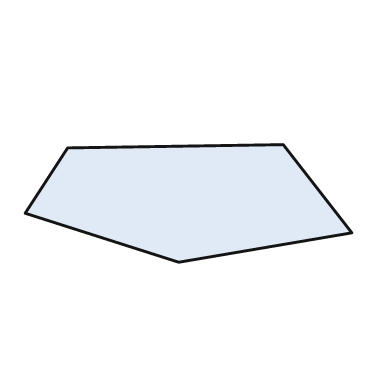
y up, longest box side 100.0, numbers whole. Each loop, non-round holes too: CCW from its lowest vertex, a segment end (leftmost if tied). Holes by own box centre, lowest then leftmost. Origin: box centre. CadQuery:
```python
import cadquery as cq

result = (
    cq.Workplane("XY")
    .moveTo(-3.0, -18.0)
    .lineTo(50.0, -9.0)
    .lineTo(29.0, 18.0)
    .lineTo(-37.0, 17.0)
    .lineTo(-50.0, -3.0)
    .close()
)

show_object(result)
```